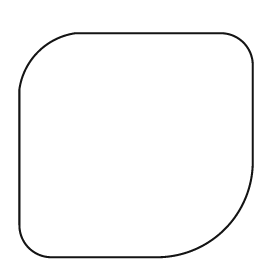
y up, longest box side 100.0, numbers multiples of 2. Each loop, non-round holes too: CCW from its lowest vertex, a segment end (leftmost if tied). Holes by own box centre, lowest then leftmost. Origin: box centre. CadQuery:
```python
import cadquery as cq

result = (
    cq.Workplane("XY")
    .moveTo(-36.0, -48.0)
    .lineTo(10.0, -48.0)
    .threePointArc((38.0, -36.0), (50.0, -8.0))
    .lineTo(50.0, 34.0)
    .threePointArc((46.0, 44.0), (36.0, 48.0))
    .lineTo(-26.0, 48.0)
    .threePointArc((-42.0, 40.0), (-50.0, 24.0))
    .lineTo(-50.0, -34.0)
    .threePointArc((-46.0, -44.0), (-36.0, -48.0))
    .close()
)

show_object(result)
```